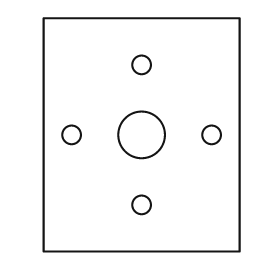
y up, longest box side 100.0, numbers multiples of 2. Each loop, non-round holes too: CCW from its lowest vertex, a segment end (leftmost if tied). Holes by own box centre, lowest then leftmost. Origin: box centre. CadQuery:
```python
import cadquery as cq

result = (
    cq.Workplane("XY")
    .moveTo(-42.0, -50.0)
    .lineTo(42.0, -50.0)
    .lineTo(42.0, 50.0)
    .lineTo(-42.0, 50.0)
    .close()
    .moveTo(0.0, -30.0)
    .circle(4.0)
    .moveTo(-30.0, 0.0)
    .circle(4.0)
    .moveTo(0.0, 0.0)
    .circle(10.0)
    .moveTo(30.0, 0.0)
    .circle(4.0)
    .moveTo(0.0, 30.0)
    .circle(4.0)
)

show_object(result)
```